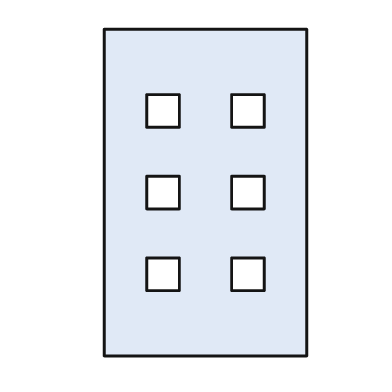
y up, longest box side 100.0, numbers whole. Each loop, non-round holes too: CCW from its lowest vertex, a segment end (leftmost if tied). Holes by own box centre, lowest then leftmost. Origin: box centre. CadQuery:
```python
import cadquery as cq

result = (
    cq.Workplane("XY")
    .moveTo(-31.0, -50.0)
    .lineTo(31.0, -50.0)
    .lineTo(31.0, 50.0)
    .lineTo(-31.0, 50.0)
    .close()
    .moveTo(-18.0, -30.0)
    .lineTo(-8.0, -30.0)
    .lineTo(-8.0, -20.0)
    .lineTo(-18.0, -20.0)
    .close()
    .moveTo(8.0, -30.0)
    .lineTo(18.0, -30.0)
    .lineTo(18.0, -20.0)
    .lineTo(8.0, -20.0)
    .close()
    .moveTo(-18.0, -5.0)
    .lineTo(-8.0, -5.0)
    .lineTo(-8.0, 5.0)
    .lineTo(-18.0, 5.0)
    .close()
    .moveTo(8.0, -5.0)
    .lineTo(18.0, -5.0)
    .lineTo(18.0, 5.0)
    .lineTo(8.0, 5.0)
    .close()
    .moveTo(-18.0, 20.0)
    .lineTo(-8.0, 20.0)
    .lineTo(-8.0, 30.0)
    .lineTo(-18.0, 30.0)
    .close()
    .moveTo(8.0, 20.0)
    .lineTo(18.0, 20.0)
    .lineTo(18.0, 30.0)
    .lineTo(8.0, 30.0)
    .close()
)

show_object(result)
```